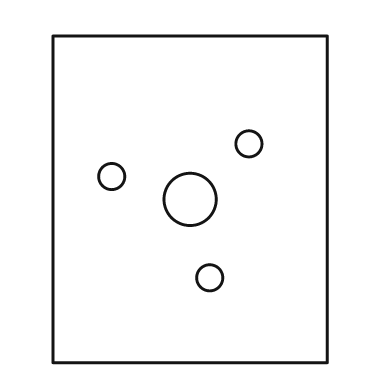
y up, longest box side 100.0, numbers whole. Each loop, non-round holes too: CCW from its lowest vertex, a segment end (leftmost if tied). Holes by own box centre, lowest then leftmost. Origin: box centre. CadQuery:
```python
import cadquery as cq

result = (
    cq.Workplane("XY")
    .moveTo(-42.0, -50.0)
    .lineTo(42.0, -50.0)
    .lineTo(42.0, 50.0)
    .lineTo(-42.0, 50.0)
    .close()
    .moveTo(6.0, -24.0)
    .circle(4.0)
    .moveTo(0.0, 0.0)
    .circle(8.0)
    .moveTo(-24.0, 7.0)
    .circle(4.0)
    .moveTo(18.0, 17.0)
    .circle(4.0)
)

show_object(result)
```